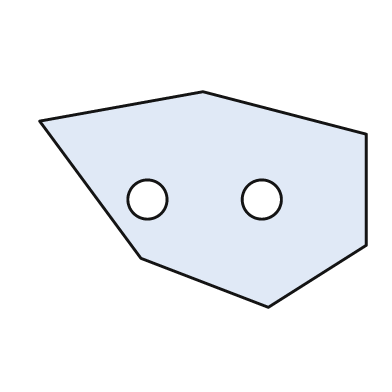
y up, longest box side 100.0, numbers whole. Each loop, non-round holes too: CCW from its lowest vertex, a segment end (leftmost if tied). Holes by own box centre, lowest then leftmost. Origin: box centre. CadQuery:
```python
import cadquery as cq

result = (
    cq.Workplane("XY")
    .moveTo(20.0, -33.0)
    .lineTo(50.0, -14.0)
    .lineTo(50.0, 20.0)
    .lineTo(0.0, 33.0)
    .lineTo(-50.0, 24.0)
    .lineTo(-19.0, -18.0)
    .close()
    .moveTo(-17.0, 0.0)
    .circle(6.0)
    .moveTo(18.0, 0.0)
    .circle(6.0)
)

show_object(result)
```